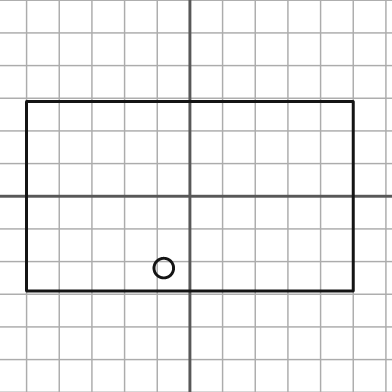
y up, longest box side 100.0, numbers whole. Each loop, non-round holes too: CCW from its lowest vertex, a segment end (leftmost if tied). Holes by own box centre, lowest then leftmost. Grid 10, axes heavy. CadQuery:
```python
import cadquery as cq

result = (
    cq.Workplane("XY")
    .moveTo(-50.0, -29.0)
    .lineTo(50.0, -29.0)
    .lineTo(50.0, 29.0)
    .lineTo(-50.0, 29.0)
    .close()
    .moveTo(-8.0, -22.0)
    .circle(3.0)
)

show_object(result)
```